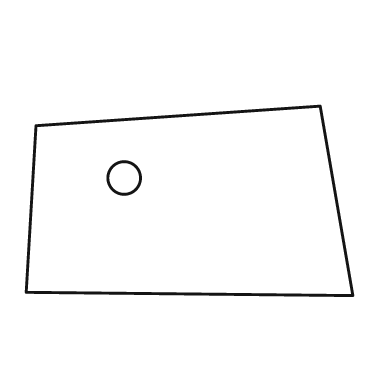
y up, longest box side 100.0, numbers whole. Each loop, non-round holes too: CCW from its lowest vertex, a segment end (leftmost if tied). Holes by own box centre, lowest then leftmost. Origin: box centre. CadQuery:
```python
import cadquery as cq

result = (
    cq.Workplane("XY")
    .moveTo(50.0, -29.0)
    .lineTo(40.0, 29.0)
    .lineTo(-47.0, 23.0)
    .lineTo(-50.0, -28.0)
    .close()
    .moveTo(-20.0, 7.0)
    .circle(5.0)
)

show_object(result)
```